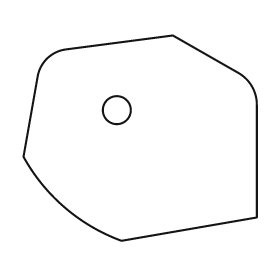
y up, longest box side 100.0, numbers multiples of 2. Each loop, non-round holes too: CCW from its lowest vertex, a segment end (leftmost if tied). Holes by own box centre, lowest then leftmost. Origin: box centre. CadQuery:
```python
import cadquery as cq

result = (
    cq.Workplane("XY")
    .moveTo(-8.0, -44.0)
    .lineTo(50.0, -34.0)
    .lineTo(50.0, 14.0)
    .threePointArc((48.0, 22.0), (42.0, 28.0))
    .lineTo(14.0, 44.0)
    .lineTo(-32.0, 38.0)
    .threePointArc((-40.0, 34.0), (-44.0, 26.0))
    .lineTo(-50.0, -8.0)
    .threePointArc((-32.0, -30.0), (-8.0, -44.0))
    .close()
    .moveTo(-10.0, 12.0)
    .circle(6.0)
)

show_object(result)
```